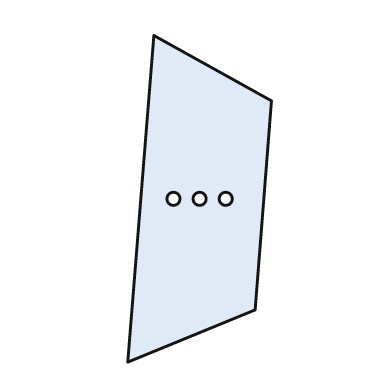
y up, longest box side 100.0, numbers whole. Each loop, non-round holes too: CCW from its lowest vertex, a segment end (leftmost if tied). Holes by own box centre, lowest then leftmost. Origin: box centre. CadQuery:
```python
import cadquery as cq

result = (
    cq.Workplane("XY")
    .moveTo(-22.0, -50.0)
    .lineTo(17.0, -34.0)
    .lineTo(22.0, 30.0)
    .lineTo(-14.0, 50.0)
    .close()
    .moveTo(-8.0, 0.0)
    .circle(2.0)
    .moveTo(0.0, 0.0)
    .circle(2.0)
    .moveTo(8.0, 0.0)
    .circle(2.0)
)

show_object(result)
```